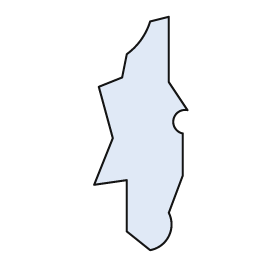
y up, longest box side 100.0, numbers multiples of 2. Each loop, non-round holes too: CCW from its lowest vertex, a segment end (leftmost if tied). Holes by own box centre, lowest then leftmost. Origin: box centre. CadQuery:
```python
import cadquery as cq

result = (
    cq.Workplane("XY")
    .moveTo(4.0, -50.0)
    .threePointArc((12.0, -44.0), (12.0, -34.0))
    .lineTo(18.0, -18.0)
    .lineTo(18.0, 0.0)
    .threePointArc((14.0, 6.0), (20.0, 10.0))
    .lineTo(12.0, 22.0)
    .lineTo(12.0, 50.0)
    .lineTo(4.0, 48.0)
    .threePointArc((0.0, 40.0), (-6.0, 34.0))
    .lineTo(-8.0, 24.0)
    .lineTo(-18.0, 20.0)
    .lineTo(-12.0, -2.0)
    .lineTo(-20.0, -22.0)
    .lineTo(-6.0, -20.0)
    .lineTo(-6.0, -42.0)
    .close()
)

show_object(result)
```